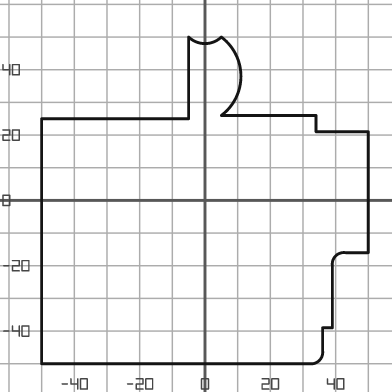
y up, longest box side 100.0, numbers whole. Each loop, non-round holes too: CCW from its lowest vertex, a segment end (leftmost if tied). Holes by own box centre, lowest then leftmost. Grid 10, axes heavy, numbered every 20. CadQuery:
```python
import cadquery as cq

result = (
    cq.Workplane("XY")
    .moveTo(-50.0, -50.0)
    .lineTo(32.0, -50.0)
    .threePointArc((35.0, -49.0), (36.0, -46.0))
    .lineTo(36.0, -39.0)
    .lineTo(39.0, -39.0)
    .lineTo(39.0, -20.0)
    .threePointArc((40.0, -17.0), (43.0, -16.0))
    .lineTo(50.0, -16.0)
    .lineTo(50.0, 21.0)
    .lineTo(34.0, 21.0)
    .lineTo(34.0, 26.0)
    .lineTo(5.0, 26.0)
    .threePointArc((11.0, 38.0), (5.0, 50.0))
    .threePointArc((0.0, 48.0), (-5.0, 50.0))
    .lineTo(-5.0, 25.0)
    .lineTo(-50.0, 25.0)
    .close()
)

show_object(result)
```